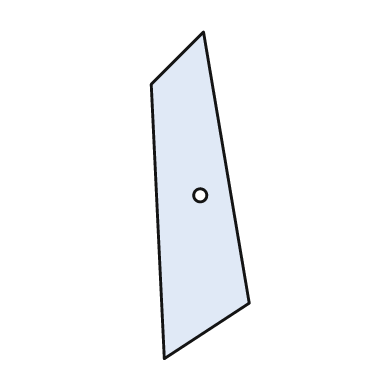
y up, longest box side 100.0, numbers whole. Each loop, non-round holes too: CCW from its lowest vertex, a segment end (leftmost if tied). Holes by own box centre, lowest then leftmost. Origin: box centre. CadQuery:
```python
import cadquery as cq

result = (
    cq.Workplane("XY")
    .moveTo(-11.0, -50.0)
    .lineTo(15.0, -33.0)
    .lineTo(1.0, 50.0)
    .lineTo(-15.0, 34.0)
    .close()
    .moveTo(0.0, 0.0)
    .circle(2.0)
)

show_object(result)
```